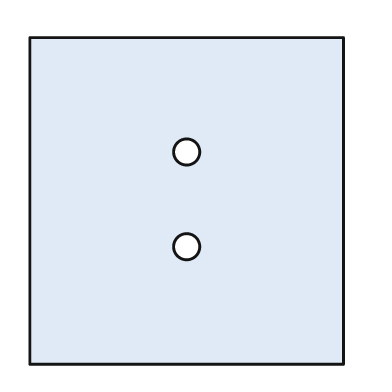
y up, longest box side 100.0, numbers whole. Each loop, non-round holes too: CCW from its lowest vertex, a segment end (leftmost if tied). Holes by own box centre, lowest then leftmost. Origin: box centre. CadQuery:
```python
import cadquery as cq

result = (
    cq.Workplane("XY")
    .moveTo(-48.0, -50.0)
    .lineTo(48.0, -50.0)
    .lineTo(48.0, 50.0)
    .lineTo(-48.0, 50.0)
    .close()
    .moveTo(0.0, -14.0)
    .circle(4.0)
    .moveTo(0.0, 15.0)
    .circle(4.0)
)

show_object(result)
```